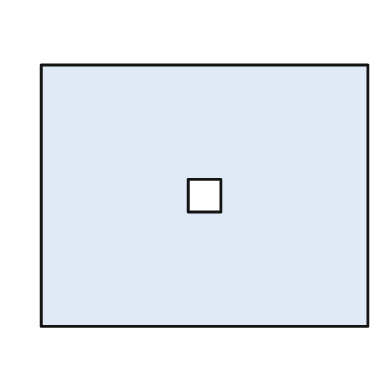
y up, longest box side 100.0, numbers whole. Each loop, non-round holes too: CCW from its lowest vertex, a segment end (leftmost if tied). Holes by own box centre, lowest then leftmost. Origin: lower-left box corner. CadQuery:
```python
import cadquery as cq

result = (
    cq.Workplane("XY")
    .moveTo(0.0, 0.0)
    .lineTo(100.0, 0.0)
    .lineTo(100.0, 80.0)
    .lineTo(0.0, 80.0)
    .close()
    .moveTo(45.0, 35.0)
    .lineTo(55.0, 35.0)
    .lineTo(55.0, 45.0)
    .lineTo(45.0, 45.0)
    .close()
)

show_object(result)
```